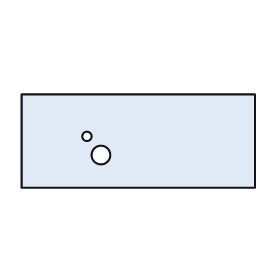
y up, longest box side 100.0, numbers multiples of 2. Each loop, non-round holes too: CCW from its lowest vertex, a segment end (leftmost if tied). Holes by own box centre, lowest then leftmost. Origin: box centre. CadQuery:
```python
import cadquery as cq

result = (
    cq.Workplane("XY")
    .moveTo(-50.0, -20.0)
    .lineTo(50.0, -20.0)
    .lineTo(50.0, 20.0)
    .lineTo(-50.0, 20.0)
    .close()
    .moveTo(-16.0, -6.0)
    .circle(4.0)
    .moveTo(-22.0, 2.0)
    .circle(2.0)
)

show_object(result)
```